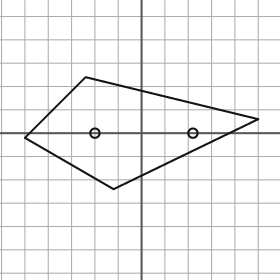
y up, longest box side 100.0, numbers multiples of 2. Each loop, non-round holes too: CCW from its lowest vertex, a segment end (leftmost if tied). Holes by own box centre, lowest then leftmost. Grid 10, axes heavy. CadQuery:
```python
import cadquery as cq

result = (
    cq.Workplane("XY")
    .moveTo(-12.0, -24.0)
    .lineTo(50.0, 6.0)
    .lineTo(-24.0, 24.0)
    .lineTo(-50.0, -2.0)
    .close()
    .moveTo(-20.0, 0.0)
    .circle(2.0)
    .moveTo(22.0, 0.0)
    .circle(2.0)
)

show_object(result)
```